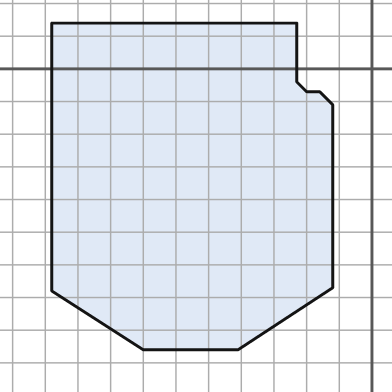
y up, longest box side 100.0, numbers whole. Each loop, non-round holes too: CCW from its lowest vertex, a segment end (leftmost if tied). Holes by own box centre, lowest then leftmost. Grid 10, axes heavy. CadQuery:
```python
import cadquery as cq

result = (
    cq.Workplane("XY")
    .moveTo(-70.0, -86.0)
    .lineTo(-41.0, -86.0)
    .lineTo(-12.0, -67.0)
    .lineTo(-12.0, -11.0)
    .lineTo(-16.0, -7.0)
    .lineTo(-20.0, -7.0)
    .lineTo(-23.0, -4.0)
    .lineTo(-23.0, 14.0)
    .lineTo(-98.0, 14.0)
    .lineTo(-98.0, -68.0)
    .close()
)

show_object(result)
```